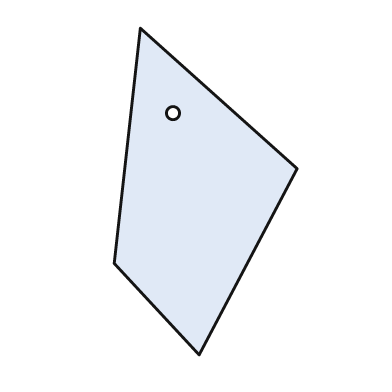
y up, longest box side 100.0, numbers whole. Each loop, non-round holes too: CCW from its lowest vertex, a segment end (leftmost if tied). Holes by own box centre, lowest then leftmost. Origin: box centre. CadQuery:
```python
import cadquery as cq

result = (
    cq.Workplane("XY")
    .moveTo(-2.0, -50.0)
    .lineTo(28.0, 7.0)
    .lineTo(-20.0, 50.0)
    .lineTo(-28.0, -22.0)
    .close()
    .moveTo(-10.0, 24.0)
    .circle(2.0)
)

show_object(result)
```